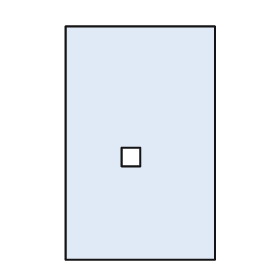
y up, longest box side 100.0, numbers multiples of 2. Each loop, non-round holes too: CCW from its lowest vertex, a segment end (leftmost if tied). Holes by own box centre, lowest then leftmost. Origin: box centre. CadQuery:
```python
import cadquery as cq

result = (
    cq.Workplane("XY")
    .moveTo(-32.0, -50.0)
    .lineTo(32.0, -50.0)
    .lineTo(32.0, 50.0)
    .lineTo(-32.0, 50.0)
    .close()
    .moveTo(-8.0, -10.0)
    .lineTo(0.0, -10.0)
    .lineTo(0.0, -2.0)
    .lineTo(-8.0, -2.0)
    .close()
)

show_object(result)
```